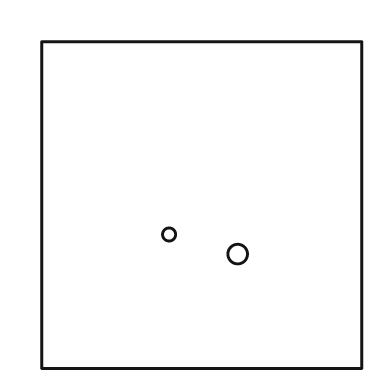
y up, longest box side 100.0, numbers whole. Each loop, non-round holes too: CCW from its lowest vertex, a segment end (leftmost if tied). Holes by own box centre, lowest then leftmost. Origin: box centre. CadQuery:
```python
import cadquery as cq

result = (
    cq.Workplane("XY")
    .moveTo(-49.0, -50.0)
    .lineTo(49.0, -50.0)
    .lineTo(49.0, 50.0)
    .lineTo(-49.0, 50.0)
    .close()
    .moveTo(11.0, -15.0)
    .circle(3.0)
    .moveTo(-10.0, -9.0)
    .circle(2.0)
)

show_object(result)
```